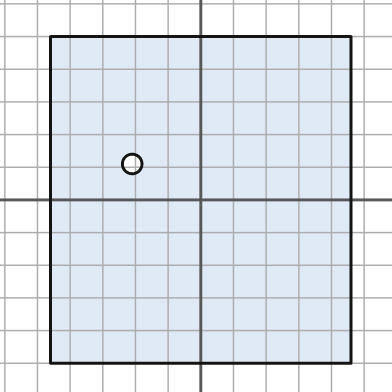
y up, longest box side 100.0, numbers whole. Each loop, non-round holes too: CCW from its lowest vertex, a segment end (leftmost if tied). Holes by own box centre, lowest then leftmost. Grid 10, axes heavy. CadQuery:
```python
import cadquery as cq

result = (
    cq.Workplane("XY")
    .moveTo(-46.0, -50.0)
    .lineTo(46.0, -50.0)
    .lineTo(46.0, 50.0)
    .lineTo(-46.0, 50.0)
    .close()
    .moveTo(-21.0, 11.0)
    .circle(3.0)
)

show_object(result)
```